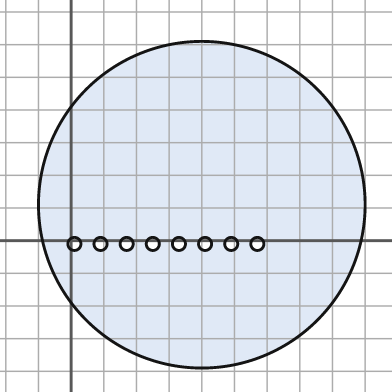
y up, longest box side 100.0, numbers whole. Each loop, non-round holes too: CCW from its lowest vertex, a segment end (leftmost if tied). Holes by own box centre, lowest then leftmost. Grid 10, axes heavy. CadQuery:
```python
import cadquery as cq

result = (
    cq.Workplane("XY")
    .moveTo(40.0, 11.0)
    .circle(50.0)
    .moveTo(1.0, -1.0)
    .circle(2.0)
    .moveTo(9.0, -1.0)
    .circle(2.0)
    .moveTo(17.0, -1.0)
    .circle(2.0)
    .moveTo(25.0, -1.0)
    .circle(2.0)
    .moveTo(33.0, -1.0)
    .circle(2.0)
    .moveTo(41.0, -1.0)
    .circle(2.0)
    .moveTo(49.0, -1.0)
    .circle(2.0)
    .moveTo(57.0, -1.0)
    .circle(2.0)
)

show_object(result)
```